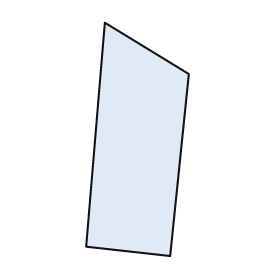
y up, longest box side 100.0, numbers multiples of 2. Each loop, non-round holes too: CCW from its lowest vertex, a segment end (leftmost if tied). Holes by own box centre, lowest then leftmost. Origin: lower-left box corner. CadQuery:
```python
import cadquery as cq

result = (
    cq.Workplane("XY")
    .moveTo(36.0, 0.0)
    .lineTo(44.0, 78.0)
    .lineTo(8.0, 100.0)
    .lineTo(0.0, 4.0)
    .close()
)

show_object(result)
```